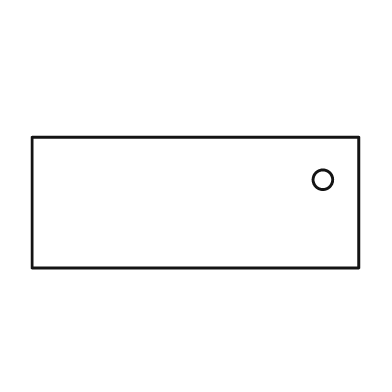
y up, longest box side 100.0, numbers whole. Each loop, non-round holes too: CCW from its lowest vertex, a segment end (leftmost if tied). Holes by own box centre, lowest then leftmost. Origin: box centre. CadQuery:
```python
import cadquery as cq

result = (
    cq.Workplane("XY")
    .moveTo(-50.0, -20.0)
    .lineTo(50.0, -20.0)
    .lineTo(50.0, 20.0)
    .lineTo(-50.0, 20.0)
    .close()
    .moveTo(39.0, 7.0)
    .circle(3.0)
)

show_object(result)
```